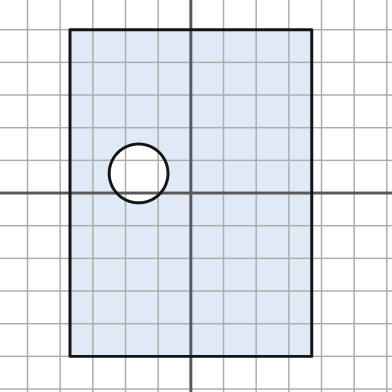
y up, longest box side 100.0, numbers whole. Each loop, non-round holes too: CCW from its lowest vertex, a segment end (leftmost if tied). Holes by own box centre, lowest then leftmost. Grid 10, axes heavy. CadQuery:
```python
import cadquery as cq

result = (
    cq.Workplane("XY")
    .moveTo(-37.0, -50.0)
    .lineTo(37.0, -50.0)
    .lineTo(37.0, 50.0)
    .lineTo(-37.0, 50.0)
    .close()
    .moveTo(-16.0, 6.0)
    .circle(9.0)
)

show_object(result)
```